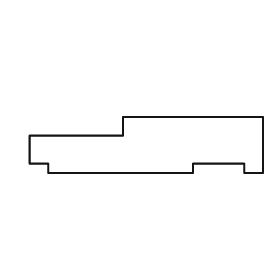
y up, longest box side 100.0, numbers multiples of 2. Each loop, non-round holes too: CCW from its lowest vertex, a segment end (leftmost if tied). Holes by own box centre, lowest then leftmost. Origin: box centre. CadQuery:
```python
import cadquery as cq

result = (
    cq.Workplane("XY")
    .moveTo(-42.0, -12.0)
    .lineTo(20.0, -12.0)
    .lineTo(20.0, -8.0)
    .lineTo(42.0, -8.0)
    .lineTo(42.0, -12.0)
    .lineTo(50.0, -12.0)
    .lineTo(50.0, 12.0)
    .lineTo(-10.0, 12.0)
    .lineTo(-10.0, 4.0)
    .lineTo(-50.0, 4.0)
    .lineTo(-50.0, -8.0)
    .lineTo(-42.0, -8.0)
    .close()
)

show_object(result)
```